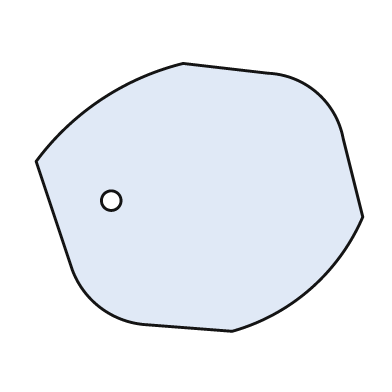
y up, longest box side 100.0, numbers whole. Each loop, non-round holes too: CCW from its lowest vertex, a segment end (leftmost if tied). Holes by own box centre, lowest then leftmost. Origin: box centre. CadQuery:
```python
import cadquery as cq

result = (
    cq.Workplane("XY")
    .moveTo(10.0, -41.0)
    .threePointArc((34.0, -28.0), (50.0, -6.0))
    .lineTo(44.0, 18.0)
    .threePointArc((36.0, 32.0), (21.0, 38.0))
    .lineTo(-5.0, 41.0)
    .threePointArc((-30.0, 30.0), (-50.0, 11.0))
    .lineTo(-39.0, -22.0)
    .threePointArc((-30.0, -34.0), (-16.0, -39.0))
    .close()
    .moveTo(-27.0, -1.0)
    .circle(3.0)
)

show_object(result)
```